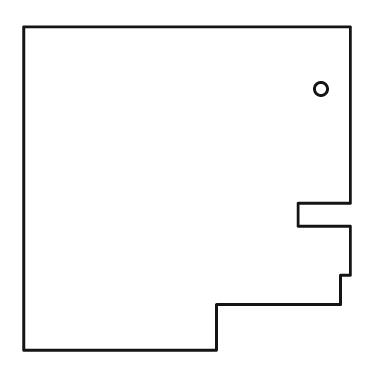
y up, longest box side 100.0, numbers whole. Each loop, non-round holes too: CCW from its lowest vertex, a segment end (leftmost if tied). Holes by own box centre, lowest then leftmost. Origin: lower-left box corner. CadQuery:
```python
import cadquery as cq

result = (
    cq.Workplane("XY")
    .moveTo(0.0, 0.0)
    .lineTo(59.0, 0.0)
    .lineTo(59.0, 14.0)
    .lineTo(97.0, 14.0)
    .lineTo(97.0, 23.0)
    .lineTo(100.0, 23.0)
    .lineTo(100.0, 38.0)
    .lineTo(84.0, 38.0)
    .lineTo(84.0, 45.0)
    .lineTo(100.0, 45.0)
    .lineTo(100.0, 99.0)
    .lineTo(0.0, 99.0)
    .close()
    .moveTo(91.0, 80.0)
    .circle(2.0)
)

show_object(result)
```